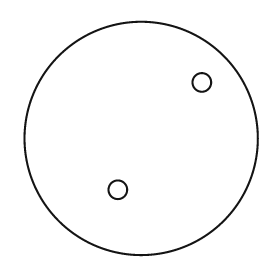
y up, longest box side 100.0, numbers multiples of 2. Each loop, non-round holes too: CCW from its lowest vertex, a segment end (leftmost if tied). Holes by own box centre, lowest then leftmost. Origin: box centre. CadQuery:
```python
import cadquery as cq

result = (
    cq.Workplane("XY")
    .moveTo(0.0, 0.0)
    .circle(50.0)
    .moveTo(-10.0, -22.0)
    .circle(4.0)
    .moveTo(26.0, 24.0)
    .circle(4.0)
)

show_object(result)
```